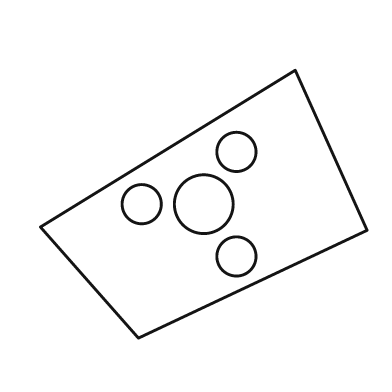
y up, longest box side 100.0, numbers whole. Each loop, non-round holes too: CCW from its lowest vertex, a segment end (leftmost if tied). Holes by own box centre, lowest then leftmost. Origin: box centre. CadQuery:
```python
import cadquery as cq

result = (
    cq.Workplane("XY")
    .moveTo(-20.0, -41.0)
    .lineTo(50.0, -8.0)
    .lineTo(28.0, 41.0)
    .lineTo(-50.0, -7.0)
    .close()
    .moveTo(10.0, -16.0)
    .circle(6.0)
    .moveTo(-19.0, 0.0)
    .circle(6.0)
    .moveTo(0.0, 0.0)
    .circle(9.0)
    .moveTo(10.0, 16.0)
    .circle(6.0)
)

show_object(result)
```